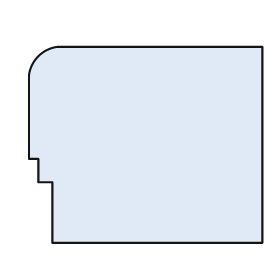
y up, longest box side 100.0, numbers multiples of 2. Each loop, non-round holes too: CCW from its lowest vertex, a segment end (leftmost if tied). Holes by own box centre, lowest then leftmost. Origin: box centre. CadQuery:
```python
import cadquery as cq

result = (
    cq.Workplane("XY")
    .moveTo(-40.0, -42.0)
    .lineTo(50.0, -42.0)
    .lineTo(50.0, 42.0)
    .lineTo(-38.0, 42.0)
    .threePointArc((-46.0, 38.0), (-50.0, 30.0))
    .lineTo(-50.0, -6.0)
    .lineTo(-46.0, -6.0)
    .lineTo(-46.0, -16.0)
    .lineTo(-40.0, -16.0)
    .close()
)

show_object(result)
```